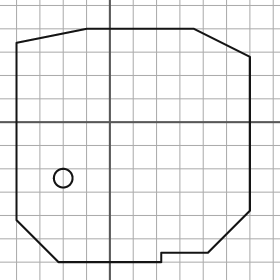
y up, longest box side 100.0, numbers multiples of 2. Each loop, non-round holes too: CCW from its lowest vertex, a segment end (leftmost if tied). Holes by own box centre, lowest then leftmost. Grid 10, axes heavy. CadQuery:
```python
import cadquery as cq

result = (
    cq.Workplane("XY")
    .moveTo(-22.0, -60.0)
    .lineTo(22.0, -60.0)
    .lineTo(22.0, -56.0)
    .lineTo(42.0, -56.0)
    .lineTo(60.0, -38.0)
    .lineTo(60.0, 28.0)
    .lineTo(36.0, 40.0)
    .lineTo(-10.0, 40.0)
    .lineTo(-40.0, 34.0)
    .lineTo(-40.0, -42.0)
    .close()
    .moveTo(-20.0, -24.0)
    .circle(4.0)
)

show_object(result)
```